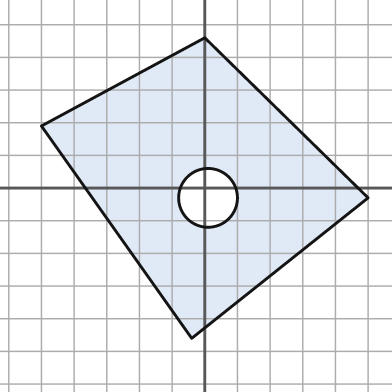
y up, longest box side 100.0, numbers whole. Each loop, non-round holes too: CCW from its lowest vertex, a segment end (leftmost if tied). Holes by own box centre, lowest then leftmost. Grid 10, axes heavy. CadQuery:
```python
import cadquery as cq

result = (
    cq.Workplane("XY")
    .moveTo(-4.0, -46.0)
    .lineTo(50.0, -3.0)
    .lineTo(0.0, 46.0)
    .lineTo(-50.0, 19.0)
    .close()
    .moveTo(1.0, -3.0)
    .circle(9.0)
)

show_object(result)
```